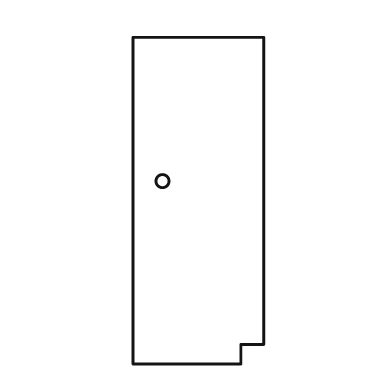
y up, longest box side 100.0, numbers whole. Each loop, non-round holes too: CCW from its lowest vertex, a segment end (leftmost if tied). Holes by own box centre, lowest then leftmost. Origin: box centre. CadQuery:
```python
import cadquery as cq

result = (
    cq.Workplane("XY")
    .moveTo(-20.0, -50.0)
    .lineTo(13.0, -50.0)
    .lineTo(13.0, -44.0)
    .lineTo(20.0, -44.0)
    .lineTo(20.0, 50.0)
    .lineTo(-20.0, 50.0)
    .close()
    .moveTo(-11.0, 6.0)
    .circle(2.0)
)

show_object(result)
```